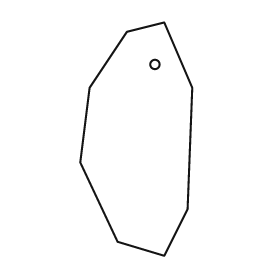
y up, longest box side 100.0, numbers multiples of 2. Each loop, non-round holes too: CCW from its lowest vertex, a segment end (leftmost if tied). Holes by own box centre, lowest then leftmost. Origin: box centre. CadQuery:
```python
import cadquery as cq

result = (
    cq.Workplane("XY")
    .moveTo(12.0, -50.0)
    .lineTo(22.0, -30.0)
    .lineTo(24.0, 22.0)
    .lineTo(12.0, 50.0)
    .lineTo(-4.0, 46.0)
    .lineTo(-20.0, 22.0)
    .lineTo(-24.0, -10.0)
    .lineTo(-8.0, -44.0)
    .close()
    .moveTo(8.0, 32.0)
    .circle(2.0)
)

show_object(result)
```